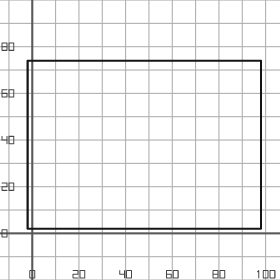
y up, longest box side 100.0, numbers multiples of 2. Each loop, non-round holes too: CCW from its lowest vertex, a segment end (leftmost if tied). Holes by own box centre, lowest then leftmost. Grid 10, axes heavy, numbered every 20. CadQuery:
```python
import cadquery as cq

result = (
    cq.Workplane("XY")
    .moveTo(-2.0, 2.0)
    .lineTo(98.0, 2.0)
    .lineTo(98.0, 74.0)
    .lineTo(-2.0, 74.0)
    .close()
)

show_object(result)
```